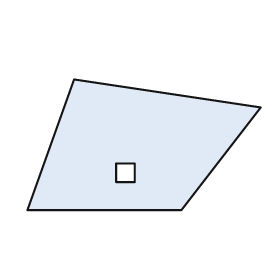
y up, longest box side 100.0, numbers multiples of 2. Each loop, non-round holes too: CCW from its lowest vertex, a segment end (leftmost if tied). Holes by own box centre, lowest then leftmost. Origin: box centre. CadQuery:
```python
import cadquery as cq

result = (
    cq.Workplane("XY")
    .moveTo(-50.0, -28.0)
    .lineTo(16.0, -28.0)
    .lineTo(50.0, 16.0)
    .lineTo(-30.0, 28.0)
    .close()
    .moveTo(-12.0, -16.0)
    .lineTo(-4.0, -16.0)
    .lineTo(-4.0, -8.0)
    .lineTo(-12.0, -8.0)
    .close()
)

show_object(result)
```